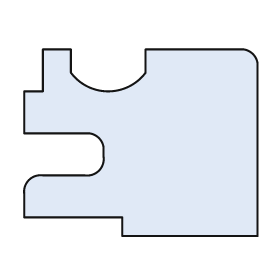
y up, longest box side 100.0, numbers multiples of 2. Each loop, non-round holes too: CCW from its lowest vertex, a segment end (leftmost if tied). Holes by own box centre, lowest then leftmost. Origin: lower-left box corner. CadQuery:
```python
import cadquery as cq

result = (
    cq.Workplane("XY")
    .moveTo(42.0, 0.0)
    .lineTo(100.0, 0.0)
    .lineTo(100.0, 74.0)
    .threePointArc((98.0, 78.0), (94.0, 80.0))
    .lineTo(52.0, 80.0)
    .lineTo(52.0, 70.0)
    .threePointArc((36.0, 62.0), (20.0, 70.0))
    .lineTo(20.0, 80.0)
    .lineTo(8.0, 80.0)
    .lineTo(8.0, 62.0)
    .lineTo(0.0, 62.0)
    .lineTo(0.0, 44.0)
    .lineTo(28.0, 44.0)
    .threePointArc((32.0, 42.0), (34.0, 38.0))
    .lineTo(34.0, 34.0)
    .threePointArc((32.0, 28.0), (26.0, 26.0))
    .lineTo(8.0, 26.0)
    .threePointArc((2.0, 24.0), (0.0, 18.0))
    .lineTo(0.0, 8.0)
    .lineTo(42.0, 8.0)
    .close()
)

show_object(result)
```